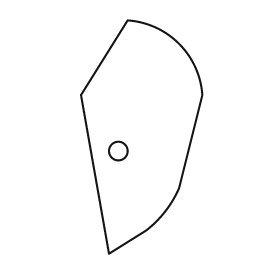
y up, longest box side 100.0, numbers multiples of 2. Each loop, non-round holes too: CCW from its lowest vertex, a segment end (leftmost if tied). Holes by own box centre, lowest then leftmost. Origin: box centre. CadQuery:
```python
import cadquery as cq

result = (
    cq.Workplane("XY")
    .moveTo(-14.0, -50.0)
    .lineTo(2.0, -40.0)
    .threePointArc((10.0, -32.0), (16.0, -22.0))
    .lineTo(26.0, 18.0)
    .threePointArc((16.0, 40.0), (-6.0, 50.0))
    .lineTo(-26.0, 18.0)
    .close()
    .moveTo(-10.0, -6.0)
    .circle(4.0)
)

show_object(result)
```